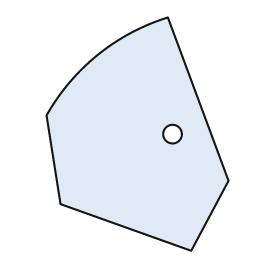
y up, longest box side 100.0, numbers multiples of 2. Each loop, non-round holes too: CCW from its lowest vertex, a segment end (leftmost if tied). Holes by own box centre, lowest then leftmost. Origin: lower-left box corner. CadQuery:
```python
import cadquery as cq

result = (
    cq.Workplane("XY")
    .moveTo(62.0, 0.0)
    .lineTo(78.0, 30.0)
    .lineTo(52.0, 100.0)
    .threePointArc((22.0, 84.0), (0.0, 58.0))
    .lineTo(6.0, 20.0)
    .close()
    .moveTo(54.0, 50.0)
    .circle(4.0)
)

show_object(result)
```